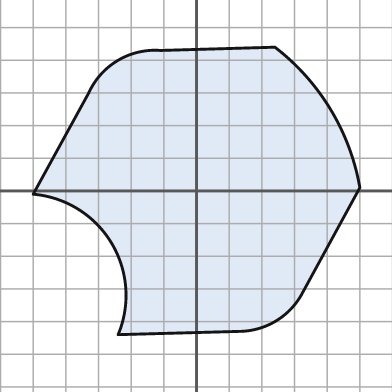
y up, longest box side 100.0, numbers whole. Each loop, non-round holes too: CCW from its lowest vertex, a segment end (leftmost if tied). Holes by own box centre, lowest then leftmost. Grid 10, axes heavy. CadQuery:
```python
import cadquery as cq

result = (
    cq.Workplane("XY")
    .moveTo(-24.0, -44.0)
    .lineTo(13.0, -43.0)
    .threePointArc((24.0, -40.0), (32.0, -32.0))
    .lineTo(50.0, 1.0)
    .threePointArc((41.0, 25.0), (24.0, 44.0))
    .lineTo(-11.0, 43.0)
    .threePointArc((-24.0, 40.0), (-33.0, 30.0))
    .lineTo(-50.0, -1.0)
    .threePointArc((-26.0, -16.0), (-24.0, -44.0))
    .close()
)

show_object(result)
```